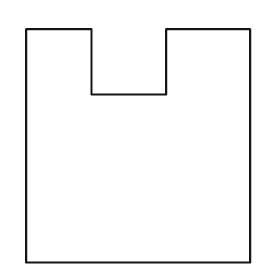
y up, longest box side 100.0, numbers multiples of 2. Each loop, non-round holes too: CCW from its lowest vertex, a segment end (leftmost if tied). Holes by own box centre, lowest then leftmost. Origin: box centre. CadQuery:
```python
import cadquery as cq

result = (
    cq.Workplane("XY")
    .moveTo(-48.0, -50.0)
    .lineTo(48.0, -50.0)
    .lineTo(48.0, 50.0)
    .lineTo(12.0, 50.0)
    .lineTo(12.0, 22.0)
    .lineTo(-20.0, 22.0)
    .lineTo(-20.0, 50.0)
    .lineTo(-48.0, 50.0)
    .close()
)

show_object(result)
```